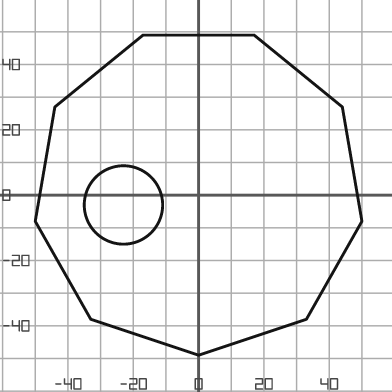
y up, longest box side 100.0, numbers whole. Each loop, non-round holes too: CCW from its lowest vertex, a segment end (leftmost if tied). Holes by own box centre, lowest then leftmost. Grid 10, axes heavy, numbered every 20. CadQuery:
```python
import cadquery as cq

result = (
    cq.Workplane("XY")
    .moveTo(0.0, -49.0)
    .lineTo(33.0, -38.0)
    .lineTo(50.0, -8.0)
    .lineTo(44.0, 27.0)
    .lineTo(17.0, 49.0)
    .lineTo(-17.0, 49.0)
    .lineTo(-44.0, 27.0)
    .lineTo(-50.0, -8.0)
    .lineTo(-33.0, -38.0)
    .close()
    .moveTo(-23.0, -3.0)
    .circle(12.0)
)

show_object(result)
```